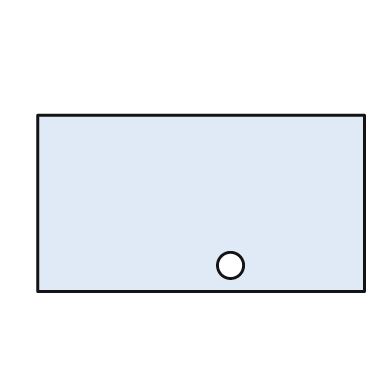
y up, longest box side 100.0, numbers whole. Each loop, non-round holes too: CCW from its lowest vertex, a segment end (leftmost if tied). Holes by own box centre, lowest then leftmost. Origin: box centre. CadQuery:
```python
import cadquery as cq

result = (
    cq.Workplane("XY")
    .moveTo(-50.0, -27.0)
    .lineTo(50.0, -27.0)
    .lineTo(50.0, 27.0)
    .lineTo(-50.0, 27.0)
    .close()
    .moveTo(9.0, -19.0)
    .circle(4.0)
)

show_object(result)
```